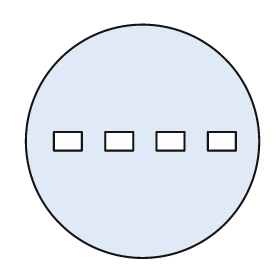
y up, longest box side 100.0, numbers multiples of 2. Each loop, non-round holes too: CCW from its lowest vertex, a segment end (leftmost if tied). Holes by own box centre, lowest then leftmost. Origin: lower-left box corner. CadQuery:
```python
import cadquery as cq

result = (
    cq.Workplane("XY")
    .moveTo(50.0, 50.0)
    .circle(50.0)
    .moveTo(12.0, 46.0)
    .lineTo(24.0, 46.0)
    .lineTo(24.0, 54.0)
    .lineTo(12.0, 54.0)
    .close()
    .moveTo(34.0, 46.0)
    .lineTo(46.0, 46.0)
    .lineTo(46.0, 54.0)
    .lineTo(34.0, 54.0)
    .close()
    .moveTo(56.0, 46.0)
    .lineTo(68.0, 46.0)
    .lineTo(68.0, 54.0)
    .lineTo(56.0, 54.0)
    .close()
    .moveTo(78.0, 46.0)
    .lineTo(90.0, 46.0)
    .lineTo(90.0, 54.0)
    .lineTo(78.0, 54.0)
    .close()
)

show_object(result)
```